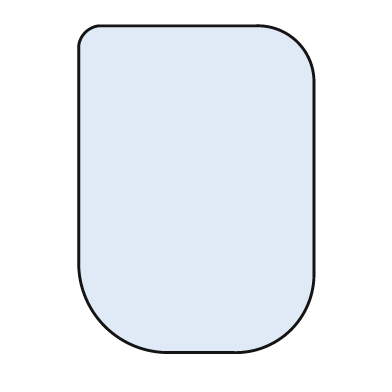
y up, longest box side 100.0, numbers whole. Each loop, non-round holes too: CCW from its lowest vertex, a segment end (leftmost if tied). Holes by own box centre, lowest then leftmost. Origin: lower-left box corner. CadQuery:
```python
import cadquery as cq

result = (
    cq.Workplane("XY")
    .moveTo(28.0, 0.0)
    .lineTo(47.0, 0.0)
    .threePointArc((65.0, 7.0), (72.0, 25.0))
    .lineTo(72.0, 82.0)
    .threePointArc((67.0, 95.0), (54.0, 100.0))
    .lineTo(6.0, 100.0)
    .threePointArc((2.0, 98.0), (0.0, 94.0))
    .lineTo(0.0, 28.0)
    .threePointArc((8.0, 8.0), (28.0, 0.0))
    .close()
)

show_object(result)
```